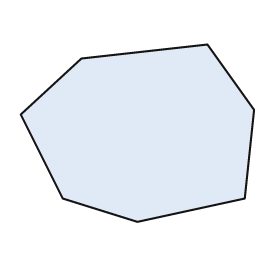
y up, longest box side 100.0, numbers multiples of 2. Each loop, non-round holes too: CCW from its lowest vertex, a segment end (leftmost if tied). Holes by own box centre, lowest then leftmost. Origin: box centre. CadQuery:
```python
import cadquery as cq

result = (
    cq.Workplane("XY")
    .moveTo(0.0, -38.0)
    .lineTo(46.0, -28.0)
    .lineTo(50.0, 10.0)
    .lineTo(30.0, 38.0)
    .lineTo(-24.0, 32.0)
    .lineTo(-50.0, 8.0)
    .lineTo(-32.0, -28.0)
    .close()
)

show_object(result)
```